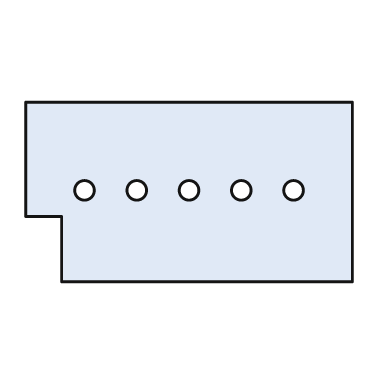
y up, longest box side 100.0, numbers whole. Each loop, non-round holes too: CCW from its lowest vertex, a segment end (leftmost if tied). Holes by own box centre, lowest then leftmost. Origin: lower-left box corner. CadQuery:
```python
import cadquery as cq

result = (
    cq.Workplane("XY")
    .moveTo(11.0, 0.0)
    .lineTo(100.0, 0.0)
    .lineTo(100.0, 55.0)
    .lineTo(0.0, 55.0)
    .lineTo(0.0, 20.0)
    .lineTo(11.0, 20.0)
    .close()
    .moveTo(18.0, 28.0)
    .circle(3.0)
    .moveTo(34.0, 28.0)
    .circle(3.0)
    .moveTo(50.0, 28.0)
    .circle(3.0)
    .moveTo(66.0, 28.0)
    .circle(3.0)
    .moveTo(82.0, 28.0)
    .circle(3.0)
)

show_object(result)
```